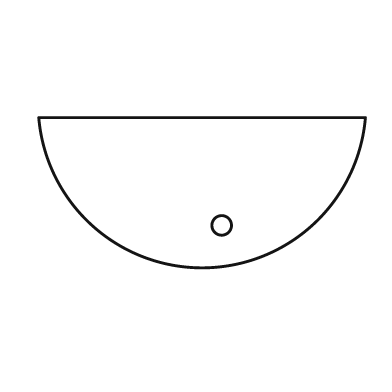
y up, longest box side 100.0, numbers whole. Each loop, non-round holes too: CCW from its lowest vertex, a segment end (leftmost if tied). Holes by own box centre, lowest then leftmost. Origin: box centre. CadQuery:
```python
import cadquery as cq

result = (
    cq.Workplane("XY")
    .moveTo(-50.0, 23.0)
    .threePointArc((0.0, -23.0), (50.0, 23.0))
    .close()
    .moveTo(6.0, -10.0)
    .circle(3.0)
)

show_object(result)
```